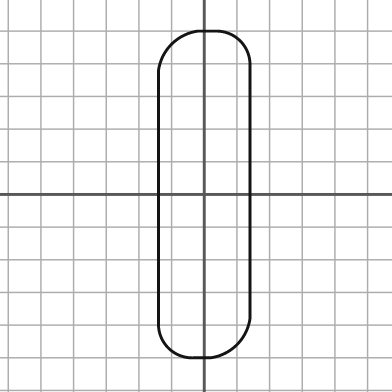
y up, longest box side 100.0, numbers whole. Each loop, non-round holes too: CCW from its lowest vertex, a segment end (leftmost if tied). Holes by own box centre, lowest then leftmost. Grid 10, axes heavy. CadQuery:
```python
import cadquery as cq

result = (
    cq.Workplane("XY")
    .moveTo(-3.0, -50.0)
    .lineTo(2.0, -50.0)
    .threePointArc((10.0, -46.0), (14.0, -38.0))
    .lineTo(14.0, 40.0)
    .threePointArc((11.0, 47.0), (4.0, 50.0))
    .lineTo(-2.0, 50.0)
    .threePointArc((-10.0, 46.0), (-14.0, 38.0))
    .lineTo(-14.0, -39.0)
    .threePointArc((-11.0, -47.0), (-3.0, -50.0))
    .close()
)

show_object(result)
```